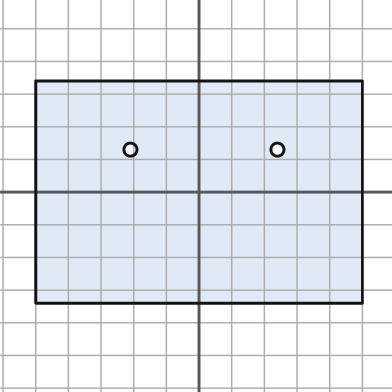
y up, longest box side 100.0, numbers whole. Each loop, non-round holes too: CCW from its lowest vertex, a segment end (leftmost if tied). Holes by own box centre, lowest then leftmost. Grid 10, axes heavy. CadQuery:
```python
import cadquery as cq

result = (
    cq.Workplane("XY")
    .moveTo(-50.0, -34.0)
    .lineTo(50.0, -34.0)
    .lineTo(50.0, 34.0)
    .lineTo(-50.0, 34.0)
    .close()
    .moveTo(-21.0, 13.0)
    .circle(2.0)
    .moveTo(24.0, 13.0)
    .circle(2.0)
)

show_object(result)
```